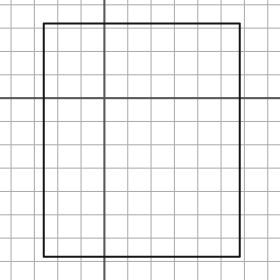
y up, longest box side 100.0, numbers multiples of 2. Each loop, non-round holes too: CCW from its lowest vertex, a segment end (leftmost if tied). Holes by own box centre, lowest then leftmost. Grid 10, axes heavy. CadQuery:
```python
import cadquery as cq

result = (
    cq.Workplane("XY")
    .moveTo(-26.0, -68.0)
    .lineTo(58.0, -68.0)
    .lineTo(58.0, 32.0)
    .lineTo(-26.0, 32.0)
    .close()
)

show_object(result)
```